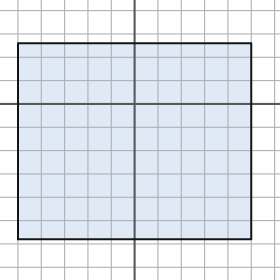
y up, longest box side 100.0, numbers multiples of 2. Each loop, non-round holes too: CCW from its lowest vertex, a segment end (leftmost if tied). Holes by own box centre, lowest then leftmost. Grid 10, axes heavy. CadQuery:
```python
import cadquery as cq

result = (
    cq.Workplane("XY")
    .moveTo(-50.0, -58.0)
    .lineTo(50.0, -58.0)
    .lineTo(50.0, 26.0)
    .lineTo(-50.0, 26.0)
    .close()
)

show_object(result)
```